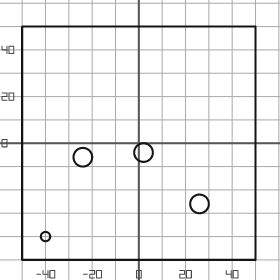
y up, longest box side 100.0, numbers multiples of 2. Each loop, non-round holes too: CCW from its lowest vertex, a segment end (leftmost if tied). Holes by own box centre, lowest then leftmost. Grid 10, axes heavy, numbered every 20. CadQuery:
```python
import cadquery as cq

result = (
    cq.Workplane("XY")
    .moveTo(-50.0, -50.0)
    .lineTo(50.0, -50.0)
    .lineTo(50.0, 50.0)
    .lineTo(-50.0, 50.0)
    .close()
    .moveTo(-40.0, -40.0)
    .circle(2.0)
    .moveTo(26.0, -26.0)
    .circle(4.0)
    .moveTo(-24.0, -6.0)
    .circle(4.0)
    .moveTo(2.0, -4.0)
    .circle(4.0)
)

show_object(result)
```